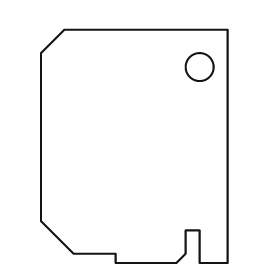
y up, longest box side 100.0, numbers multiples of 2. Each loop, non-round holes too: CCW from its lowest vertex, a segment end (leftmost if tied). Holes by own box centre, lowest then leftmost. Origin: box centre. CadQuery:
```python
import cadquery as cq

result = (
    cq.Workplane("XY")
    .moveTo(-8.0, -50.0)
    .lineTo(18.0, -50.0)
    .lineTo(22.0, -46.0)
    .lineTo(22.0, -36.0)
    .lineTo(28.0, -36.0)
    .lineTo(28.0, -50.0)
    .lineTo(40.0, -50.0)
    .lineTo(40.0, 50.0)
    .lineTo(-30.0, 50.0)
    .lineTo(-40.0, 40.0)
    .lineTo(-40.0, -32.0)
    .lineTo(-26.0, -46.0)
    .lineTo(-8.0, -46.0)
    .close()
    .moveTo(28.0, 34.0)
    .circle(6.0)
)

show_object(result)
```